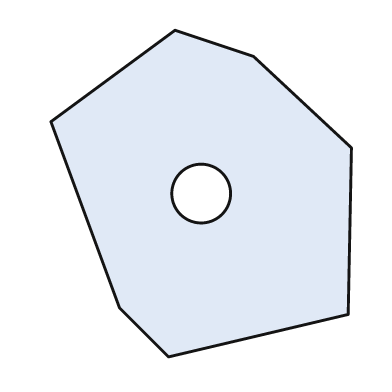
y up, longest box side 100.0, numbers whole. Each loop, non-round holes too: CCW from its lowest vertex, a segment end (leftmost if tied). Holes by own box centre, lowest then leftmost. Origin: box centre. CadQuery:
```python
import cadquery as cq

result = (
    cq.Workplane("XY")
    .moveTo(-10.0, -50.0)
    .lineTo(45.0, -37.0)
    .lineTo(46.0, 14.0)
    .lineTo(16.0, 42.0)
    .lineTo(-8.0, 50.0)
    .lineTo(-46.0, 22.0)
    .lineTo(-25.0, -35.0)
    .close()
    .moveTo(0.0, 0.0)
    .circle(9.0)
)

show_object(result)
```